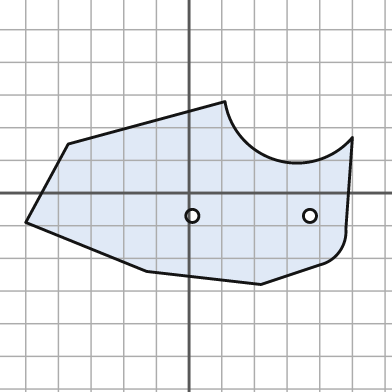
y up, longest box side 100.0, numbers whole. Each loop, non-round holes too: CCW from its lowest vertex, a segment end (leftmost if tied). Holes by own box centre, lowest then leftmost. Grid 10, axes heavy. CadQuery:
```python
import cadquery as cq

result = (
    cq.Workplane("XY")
    .moveTo(22.0, -28.0)
    .lineTo(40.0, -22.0)
    .threePointArc((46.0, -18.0), (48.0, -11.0))
    .lineTo(50.0, 17.0)
    .threePointArc((27.0, 10.0), (11.0, 28.0))
    .lineTo(-37.0, 15.0)
    .lineTo(-50.0, -9.0)
    .lineTo(-13.0, -24.0)
    .close()
    .moveTo(1.0, -7.0)
    .circle(2.0)
    .moveTo(37.0, -7.0)
    .circle(2.0)
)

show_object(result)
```